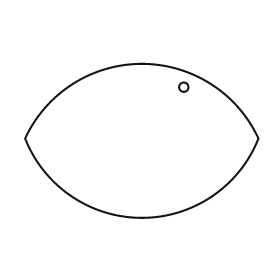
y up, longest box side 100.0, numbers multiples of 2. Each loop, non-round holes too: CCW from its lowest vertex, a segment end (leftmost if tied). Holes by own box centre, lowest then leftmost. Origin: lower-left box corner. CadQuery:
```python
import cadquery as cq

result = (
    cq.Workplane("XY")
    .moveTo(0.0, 34.0)
    .threePointArc((50.0, 0.0), (100.0, 34.0))
    .threePointArc((50.0, 66.0), (0.0, 34.0))
    .close()
    .moveTo(68.0, 56.0)
    .circle(2.0)
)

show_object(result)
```